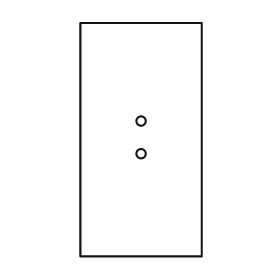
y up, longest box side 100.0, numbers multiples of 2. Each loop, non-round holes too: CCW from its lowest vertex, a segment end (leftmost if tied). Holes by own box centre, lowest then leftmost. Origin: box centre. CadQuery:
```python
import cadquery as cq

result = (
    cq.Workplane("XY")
    .moveTo(-26.0, -50.0)
    .lineTo(26.0, -50.0)
    .lineTo(26.0, 50.0)
    .lineTo(-26.0, 50.0)
    .close()
    .moveTo(0.0, -6.0)
    .circle(2.0)
    .moveTo(0.0, 8.0)
    .circle(2.0)
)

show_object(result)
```